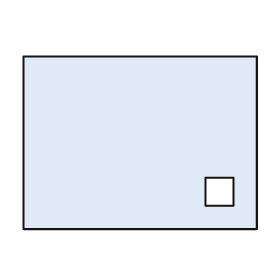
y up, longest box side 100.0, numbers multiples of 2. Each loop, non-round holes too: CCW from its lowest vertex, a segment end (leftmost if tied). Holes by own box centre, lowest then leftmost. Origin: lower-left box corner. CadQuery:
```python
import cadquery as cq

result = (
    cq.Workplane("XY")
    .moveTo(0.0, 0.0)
    .lineTo(100.0, 0.0)
    .lineTo(100.0, 74.0)
    .lineTo(0.0, 74.0)
    .close()
    .moveTo(78.0, 10.0)
    .lineTo(90.0, 10.0)
    .lineTo(90.0, 22.0)
    .lineTo(78.0, 22.0)
    .close()
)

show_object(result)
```